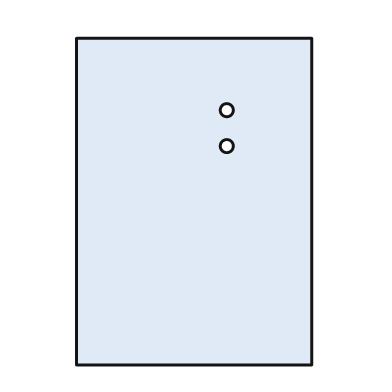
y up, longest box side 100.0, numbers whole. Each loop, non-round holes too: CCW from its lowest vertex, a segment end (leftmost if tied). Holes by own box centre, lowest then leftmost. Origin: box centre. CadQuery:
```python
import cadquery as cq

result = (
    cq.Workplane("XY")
    .moveTo(-36.0, -50.0)
    .lineTo(36.0, -50.0)
    .lineTo(36.0, 50.0)
    .lineTo(-36.0, 50.0)
    .close()
    .moveTo(10.0, 17.0)
    .circle(2.0)
    .moveTo(10.0, 28.0)
    .circle(2.0)
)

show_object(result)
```